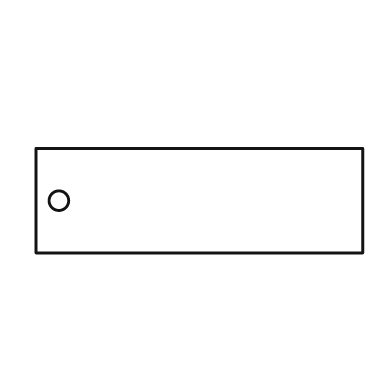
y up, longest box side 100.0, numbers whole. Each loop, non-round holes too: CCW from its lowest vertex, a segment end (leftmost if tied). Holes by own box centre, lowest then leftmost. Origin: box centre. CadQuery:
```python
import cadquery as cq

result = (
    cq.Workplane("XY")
    .moveTo(-50.0, -16.0)
    .lineTo(50.0, -16.0)
    .lineTo(50.0, 16.0)
    .lineTo(-50.0, 16.0)
    .close()
    .moveTo(-43.0, 0.0)
    .circle(3.0)
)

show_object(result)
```